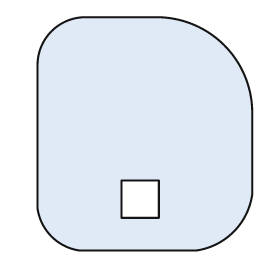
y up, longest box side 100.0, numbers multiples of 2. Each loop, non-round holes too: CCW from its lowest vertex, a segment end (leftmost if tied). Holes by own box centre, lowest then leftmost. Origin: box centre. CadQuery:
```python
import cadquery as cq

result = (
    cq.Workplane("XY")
    .moveTo(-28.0, -50.0)
    .lineTo(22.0, -50.0)
    .threePointArc((38.0, -42.0), (46.0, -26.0))
    .lineTo(46.0, 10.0)
    .threePointArc((34.0, 38.0), (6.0, 50.0))
    .lineTo(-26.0, 50.0)
    .threePointArc((-40.0, 44.0), (-46.0, 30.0))
    .lineTo(-46.0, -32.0)
    .threePointArc((-40.0, -44.0), (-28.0, -50.0))
    .close()
    .moveTo(-10.0, -36.0)
    .lineTo(6.0, -36.0)
    .lineTo(6.0, -20.0)
    .lineTo(-10.0, -20.0)
    .close()
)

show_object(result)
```